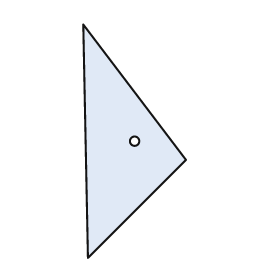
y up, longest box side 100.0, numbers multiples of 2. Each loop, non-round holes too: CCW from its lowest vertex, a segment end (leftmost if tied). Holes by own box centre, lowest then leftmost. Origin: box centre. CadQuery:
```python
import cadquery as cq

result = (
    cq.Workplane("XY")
    .moveTo(-20.0, -50.0)
    .lineTo(22.0, -8.0)
    .lineTo(-22.0, 50.0)
    .close()
    .moveTo(0.0, 0.0)
    .circle(2.0)
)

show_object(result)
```